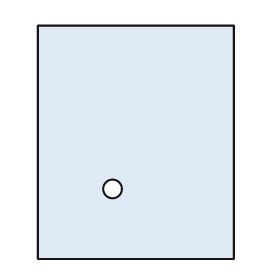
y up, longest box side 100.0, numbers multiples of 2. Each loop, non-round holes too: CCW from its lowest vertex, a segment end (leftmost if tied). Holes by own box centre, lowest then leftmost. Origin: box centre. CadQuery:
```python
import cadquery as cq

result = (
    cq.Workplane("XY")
    .moveTo(-42.0, -50.0)
    .lineTo(42.0, -50.0)
    .lineTo(42.0, 50.0)
    .lineTo(-42.0, 50.0)
    .close()
    .moveTo(-10.0, -20.0)
    .circle(4.0)
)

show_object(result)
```